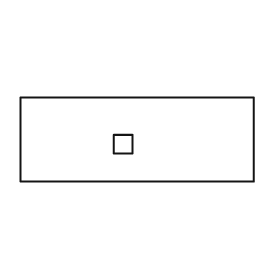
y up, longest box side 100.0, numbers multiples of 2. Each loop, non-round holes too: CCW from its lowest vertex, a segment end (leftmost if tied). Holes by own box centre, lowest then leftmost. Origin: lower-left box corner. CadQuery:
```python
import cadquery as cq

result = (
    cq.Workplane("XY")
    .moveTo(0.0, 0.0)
    .lineTo(100.0, 0.0)
    .lineTo(100.0, 36.0)
    .lineTo(0.0, 36.0)
    .close()
    .moveTo(40.0, 12.0)
    .lineTo(48.0, 12.0)
    .lineTo(48.0, 20.0)
    .lineTo(40.0, 20.0)
    .close()
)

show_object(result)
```